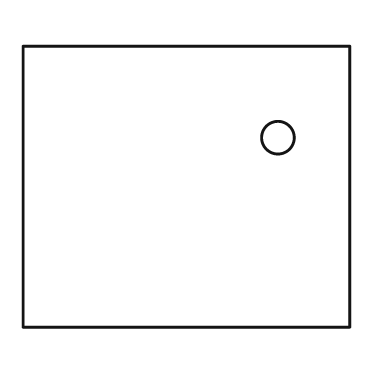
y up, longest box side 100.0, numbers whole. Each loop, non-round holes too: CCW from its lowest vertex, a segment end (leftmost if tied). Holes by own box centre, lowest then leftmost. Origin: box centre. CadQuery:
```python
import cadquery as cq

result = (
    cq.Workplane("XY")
    .moveTo(-50.0, -43.0)
    .lineTo(50.0, -43.0)
    .lineTo(50.0, 43.0)
    .lineTo(-50.0, 43.0)
    .close()
    .moveTo(28.0, 15.0)
    .circle(5.0)
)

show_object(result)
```